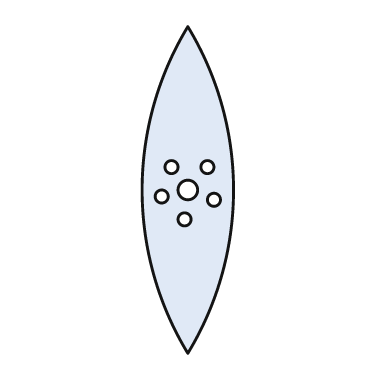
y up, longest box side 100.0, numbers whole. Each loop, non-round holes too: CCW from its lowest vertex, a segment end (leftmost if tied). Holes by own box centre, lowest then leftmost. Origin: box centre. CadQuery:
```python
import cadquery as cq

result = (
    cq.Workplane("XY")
    .moveTo(0.0, -50.0)
    .threePointArc((14.0, 0.0), (0.0, 50.0))
    .threePointArc((-14.0, 0.0), (0.0, -50.0))
    .close()
    .moveTo(-1.0, -9.0)
    .circle(2.0)
    .moveTo(8.0, -3.0)
    .circle(2.0)
    .moveTo(-8.0, -2.0)
    .circle(2.0)
    .moveTo(0.0, 0.0)
    .circle(3.0)
    .moveTo(-5.0, 7.0)
    .circle(2.0)
    .moveTo(6.0, 7.0)
    .circle(2.0)
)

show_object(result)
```